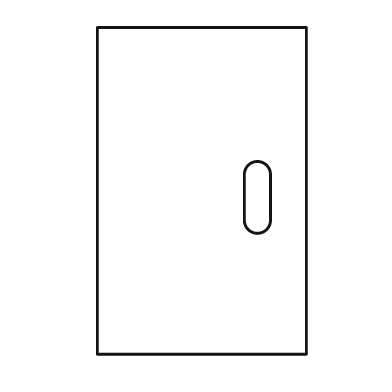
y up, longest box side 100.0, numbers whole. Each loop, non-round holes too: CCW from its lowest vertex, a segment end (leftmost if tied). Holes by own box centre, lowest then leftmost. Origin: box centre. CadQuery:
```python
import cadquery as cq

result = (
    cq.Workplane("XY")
    .moveTo(-32.0, -50.0)
    .lineTo(32.0, -50.0)
    .lineTo(32.0, 50.0)
    .lineTo(-32.0, 50.0)
    .close()
    .moveTo(13.0, -9.0)
    .threePointArc((17.0, -13.0), (21.0, -9.0))
    .lineTo(21.0, 5.0)
    .threePointArc((17.0, 9.0), (13.0, 5.0))
    .close()
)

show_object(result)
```